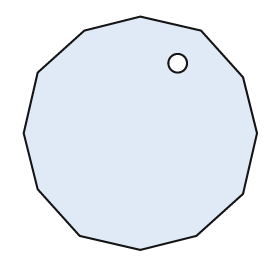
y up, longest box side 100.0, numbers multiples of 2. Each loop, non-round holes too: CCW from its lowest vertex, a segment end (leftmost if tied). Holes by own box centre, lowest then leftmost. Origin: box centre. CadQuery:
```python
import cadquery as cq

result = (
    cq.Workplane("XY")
    .moveTo(0.0, -50.0)
    .lineTo(24.0, -44.0)
    .lineTo(44.0, -26.0)
    .lineTo(50.0, 0.0)
    .lineTo(44.0, 24.0)
    .lineTo(26.0, 44.0)
    .lineTo(0.0, 50.0)
    .lineTo(-24.0, 44.0)
    .lineTo(-44.0, 26.0)
    .lineTo(-50.0, 0.0)
    .lineTo(-44.0, -24.0)
    .lineTo(-26.0, -44.0)
    .close()
    .moveTo(16.0, 30.0)
    .circle(4.0)
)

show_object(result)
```